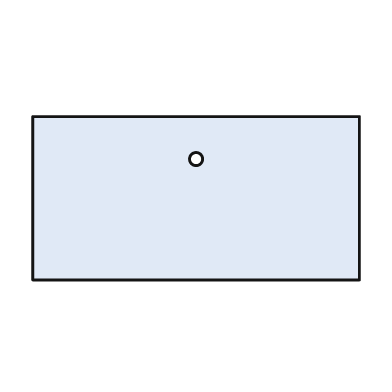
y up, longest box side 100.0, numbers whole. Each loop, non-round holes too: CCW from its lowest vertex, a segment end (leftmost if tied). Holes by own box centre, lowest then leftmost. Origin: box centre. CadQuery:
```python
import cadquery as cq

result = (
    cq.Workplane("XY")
    .moveTo(-50.0, -25.0)
    .lineTo(50.0, -25.0)
    .lineTo(50.0, 25.0)
    .lineTo(-50.0, 25.0)
    .close()
    .moveTo(0.0, 12.0)
    .circle(2.0)
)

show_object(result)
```